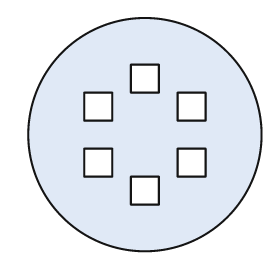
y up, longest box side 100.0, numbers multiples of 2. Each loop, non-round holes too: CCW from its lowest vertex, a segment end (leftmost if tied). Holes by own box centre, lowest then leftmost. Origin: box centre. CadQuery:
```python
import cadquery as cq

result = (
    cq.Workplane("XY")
    .moveTo(0.0, 0.0)
    .circle(50.0)
    .moveTo(-6.0, -30.0)
    .lineTo(6.0, -30.0)
    .lineTo(6.0, -18.0)
    .lineTo(-6.0, -18.0)
    .close()
    .moveTo(-26.0, -18.0)
    .lineTo(-14.0, -18.0)
    .lineTo(-14.0, -6.0)
    .lineTo(-26.0, -6.0)
    .close()
    .moveTo(14.0, -18.0)
    .lineTo(26.0, -18.0)
    .lineTo(26.0, -6.0)
    .lineTo(14.0, -6.0)
    .close()
    .moveTo(-26.0, 6.0)
    .lineTo(-14.0, 6.0)
    .lineTo(-14.0, 18.0)
    .lineTo(-26.0, 18.0)
    .close()
    .moveTo(14.0, 6.0)
    .lineTo(26.0, 6.0)
    .lineTo(26.0, 18.0)
    .lineTo(14.0, 18.0)
    .close()
    .moveTo(-6.0, 18.0)
    .lineTo(6.0, 18.0)
    .lineTo(6.0, 30.0)
    .lineTo(-6.0, 30.0)
    .close()
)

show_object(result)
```